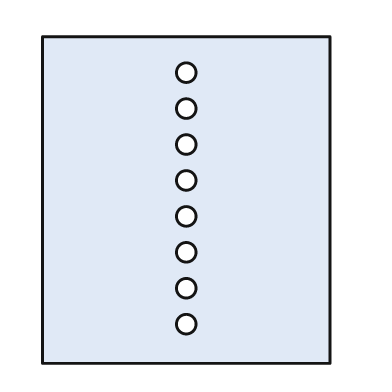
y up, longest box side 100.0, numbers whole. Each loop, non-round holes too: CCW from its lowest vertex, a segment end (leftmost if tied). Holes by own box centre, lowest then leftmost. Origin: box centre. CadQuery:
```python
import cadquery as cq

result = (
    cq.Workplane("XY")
    .moveTo(-44.0, -50.0)
    .lineTo(44.0, -50.0)
    .lineTo(44.0, 50.0)
    .lineTo(-44.0, 50.0)
    .close()
    .moveTo(0.0, -38.0)
    .circle(3.0)
    .moveTo(0.0, -27.0)
    .circle(3.0)
    .moveTo(0.0, -16.0)
    .circle(3.0)
    .moveTo(0.0, -5.0)
    .circle(3.0)
    .moveTo(0.0, 6.0)
    .circle(3.0)
    .moveTo(0.0, 17.0)
    .circle(3.0)
    .moveTo(0.0, 28.0)
    .circle(3.0)
    .moveTo(0.0, 39.0)
    .circle(3.0)
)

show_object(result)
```